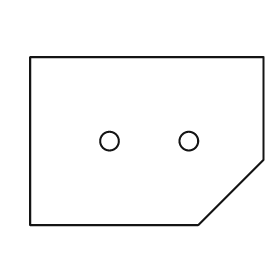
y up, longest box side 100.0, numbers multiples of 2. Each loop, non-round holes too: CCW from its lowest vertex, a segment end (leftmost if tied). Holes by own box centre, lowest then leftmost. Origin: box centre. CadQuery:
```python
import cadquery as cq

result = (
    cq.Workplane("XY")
    .moveTo(-50.0, -36.0)
    .lineTo(22.0, -36.0)
    .lineTo(50.0, -8.0)
    .lineTo(50.0, 36.0)
    .lineTo(-50.0, 36.0)
    .close()
    .moveTo(-16.0, 0.0)
    .circle(4.0)
    .moveTo(18.0, 0.0)
    .circle(4.0)
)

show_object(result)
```